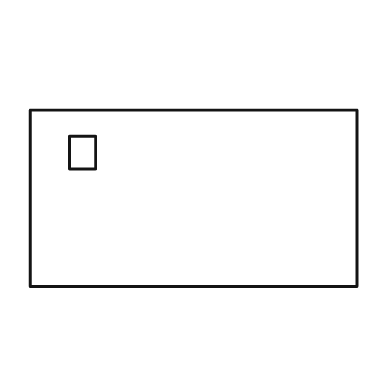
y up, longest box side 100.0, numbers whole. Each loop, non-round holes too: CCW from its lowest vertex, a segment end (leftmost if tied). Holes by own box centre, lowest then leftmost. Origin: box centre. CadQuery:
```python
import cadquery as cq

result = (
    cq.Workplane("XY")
    .moveTo(-50.0, -27.0)
    .lineTo(50.0, -27.0)
    .lineTo(50.0, 27.0)
    .lineTo(-50.0, 27.0)
    .close()
    .moveTo(-38.0, 9.0)
    .lineTo(-30.0, 9.0)
    .lineTo(-30.0, 19.0)
    .lineTo(-38.0, 19.0)
    .close()
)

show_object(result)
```